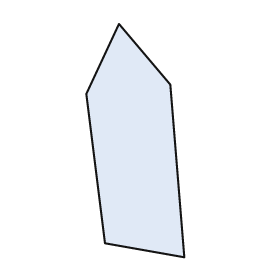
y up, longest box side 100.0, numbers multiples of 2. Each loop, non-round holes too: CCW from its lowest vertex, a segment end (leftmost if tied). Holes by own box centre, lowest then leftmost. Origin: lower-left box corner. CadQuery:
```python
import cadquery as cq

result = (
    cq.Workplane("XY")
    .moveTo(42.0, 0.0)
    .lineTo(36.0, 74.0)
    .lineTo(14.0, 100.0)
    .lineTo(0.0, 70.0)
    .lineTo(8.0, 6.0)
    .close()
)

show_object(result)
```